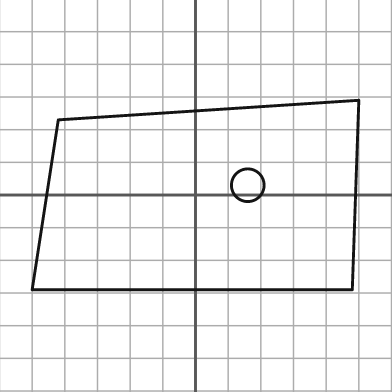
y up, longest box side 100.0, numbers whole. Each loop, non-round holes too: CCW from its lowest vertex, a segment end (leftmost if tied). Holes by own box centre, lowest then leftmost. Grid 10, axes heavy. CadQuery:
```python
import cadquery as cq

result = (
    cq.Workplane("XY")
    .moveTo(-50.0, -29.0)
    .lineTo(48.0, -29.0)
    .lineTo(50.0, 29.0)
    .lineTo(-42.0, 23.0)
    .close()
    .moveTo(16.0, 3.0)
    .circle(5.0)
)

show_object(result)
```